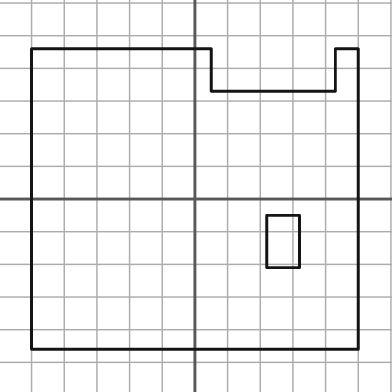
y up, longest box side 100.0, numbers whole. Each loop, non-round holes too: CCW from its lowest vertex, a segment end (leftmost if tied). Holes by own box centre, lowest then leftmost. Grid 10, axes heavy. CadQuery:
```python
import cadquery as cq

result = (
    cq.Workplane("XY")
    .moveTo(-50.0, -46.0)
    .lineTo(50.0, -46.0)
    .lineTo(50.0, 46.0)
    .lineTo(43.0, 46.0)
    .lineTo(43.0, 33.0)
    .lineTo(5.0, 33.0)
    .lineTo(5.0, 46.0)
    .lineTo(-50.0, 46.0)
    .close()
    .moveTo(22.0, -21.0)
    .lineTo(32.0, -21.0)
    .lineTo(32.0, -5.0)
    .lineTo(22.0, -5.0)
    .close()
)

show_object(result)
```